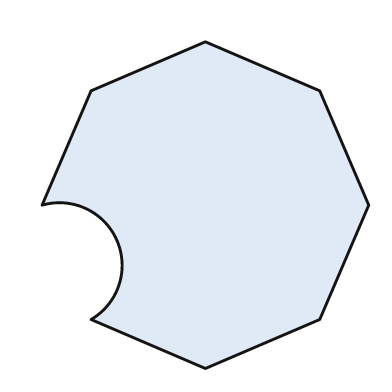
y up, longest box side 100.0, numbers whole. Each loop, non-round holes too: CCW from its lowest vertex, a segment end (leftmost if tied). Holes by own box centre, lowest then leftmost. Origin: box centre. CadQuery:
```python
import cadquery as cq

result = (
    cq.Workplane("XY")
    .moveTo(0.0, -50.0)
    .lineTo(35.0, -35.0)
    .lineTo(50.0, 0.0)
    .lineTo(35.0, 35.0)
    .lineTo(0.0, 50.0)
    .lineTo(-35.0, 35.0)
    .lineTo(-50.0, 0.0)
    .threePointArc((-27.0, -11.0), (-35.0, -35.0))
    .close()
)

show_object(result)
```